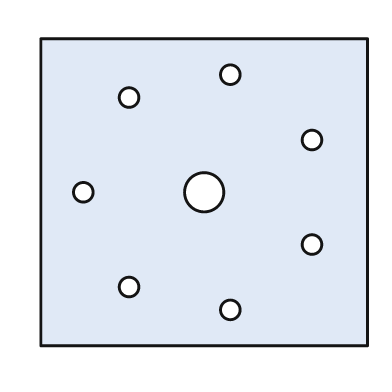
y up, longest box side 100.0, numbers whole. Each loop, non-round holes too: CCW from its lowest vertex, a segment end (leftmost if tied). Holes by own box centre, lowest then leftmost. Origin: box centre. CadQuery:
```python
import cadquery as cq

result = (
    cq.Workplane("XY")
    .moveTo(-50.0, -47.0)
    .lineTo(50.0, -47.0)
    .lineTo(50.0, 47.0)
    .lineTo(-50.0, 47.0)
    .close()
    .moveTo(8.0, -36.0)
    .circle(3.0)
    .moveTo(-23.0, -29.0)
    .circle(3.0)
    .moveTo(33.0, -16.0)
    .circle(3.0)
    .moveTo(-37.0, 0.0)
    .circle(3.0)
    .moveTo(0.0, 0.0)
    .circle(6.0)
    .moveTo(33.0, 16.0)
    .circle(3.0)
    .moveTo(-23.0, 29.0)
    .circle(3.0)
    .moveTo(8.0, 36.0)
    .circle(3.0)
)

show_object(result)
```